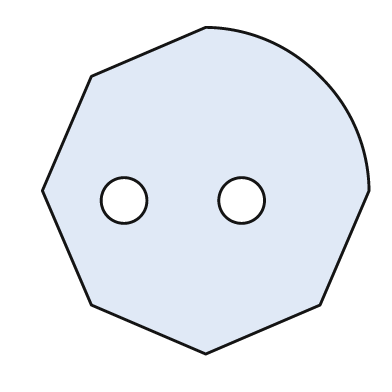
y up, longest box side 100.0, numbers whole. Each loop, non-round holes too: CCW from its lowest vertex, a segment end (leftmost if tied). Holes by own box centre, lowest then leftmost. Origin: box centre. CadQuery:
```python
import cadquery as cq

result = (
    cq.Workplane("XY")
    .moveTo(0.0, -50.0)
    .lineTo(35.0, -35.0)
    .lineTo(50.0, 0.0)
    .threePointArc((46.0, 19.0), (35.0, 35.0))
    .threePointArc((19.0, 46.0), (0.0, 50.0))
    .lineTo(-35.0, 35.0)
    .lineTo(-50.0, 0.0)
    .lineTo(-35.0, -35.0)
    .close()
    .moveTo(-25.0, -3.0)
    .circle(7.0)
    .moveTo(11.0, -3.0)
    .circle(7.0)
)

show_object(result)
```